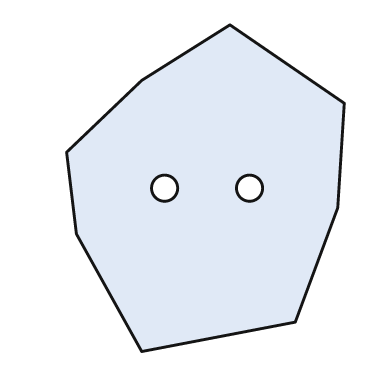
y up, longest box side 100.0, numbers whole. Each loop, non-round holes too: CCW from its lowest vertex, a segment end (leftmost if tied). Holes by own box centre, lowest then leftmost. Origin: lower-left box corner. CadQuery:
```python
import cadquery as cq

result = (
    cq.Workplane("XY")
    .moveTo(23.0, 0.0)
    .lineTo(70.0, 9.0)
    .lineTo(83.0, 44.0)
    .lineTo(85.0, 76.0)
    .lineTo(50.0, 100.0)
    .lineTo(23.0, 83.0)
    .lineTo(0.0, 61.0)
    .lineTo(3.0, 36.0)
    .close()
    .moveTo(30.0, 50.0)
    .circle(4.0)
    .moveTo(56.0, 50.0)
    .circle(4.0)
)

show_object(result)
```